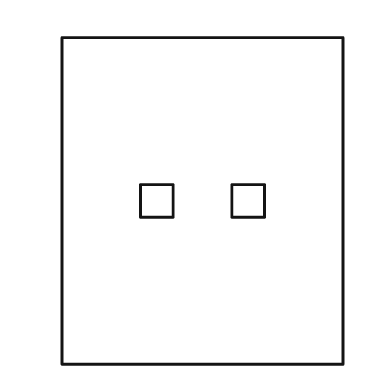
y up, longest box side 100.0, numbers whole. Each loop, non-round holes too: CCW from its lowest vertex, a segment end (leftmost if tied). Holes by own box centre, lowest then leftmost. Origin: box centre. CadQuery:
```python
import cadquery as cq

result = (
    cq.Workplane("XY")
    .moveTo(-43.0, -50.0)
    .lineTo(43.0, -50.0)
    .lineTo(43.0, 50.0)
    .lineTo(-43.0, 50.0)
    .close()
    .moveTo(-19.0, -5.0)
    .lineTo(-9.0, -5.0)
    .lineTo(-9.0, 5.0)
    .lineTo(-19.0, 5.0)
    .close()
    .moveTo(9.0, -5.0)
    .lineTo(19.0, -5.0)
    .lineTo(19.0, 5.0)
    .lineTo(9.0, 5.0)
    .close()
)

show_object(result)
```